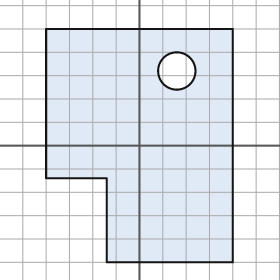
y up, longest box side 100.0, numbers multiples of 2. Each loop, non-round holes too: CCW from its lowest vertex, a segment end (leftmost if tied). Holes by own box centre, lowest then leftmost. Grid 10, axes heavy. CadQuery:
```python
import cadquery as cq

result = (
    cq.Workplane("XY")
    .moveTo(-14.0, -50.0)
    .lineTo(40.0, -50.0)
    .lineTo(40.0, 50.0)
    .lineTo(-40.0, 50.0)
    .lineTo(-40.0, -14.0)
    .lineTo(-14.0, -14.0)
    .close()
    .moveTo(16.0, 32.0)
    .circle(8.0)
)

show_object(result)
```